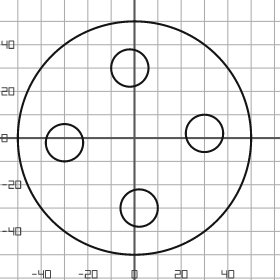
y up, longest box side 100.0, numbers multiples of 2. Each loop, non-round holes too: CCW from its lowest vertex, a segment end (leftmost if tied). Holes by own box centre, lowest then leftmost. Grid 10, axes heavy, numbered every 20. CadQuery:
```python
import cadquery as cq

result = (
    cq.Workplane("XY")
    .moveTo(0.0, 0.0)
    .circle(50.0)
    .moveTo(2.0, -30.0)
    .circle(8.0)
    .moveTo(-30.0, -2.0)
    .circle(8.0)
    .moveTo(30.0, 2.0)
    .circle(8.0)
    .moveTo(-2.0, 30.0)
    .circle(8.0)
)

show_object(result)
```